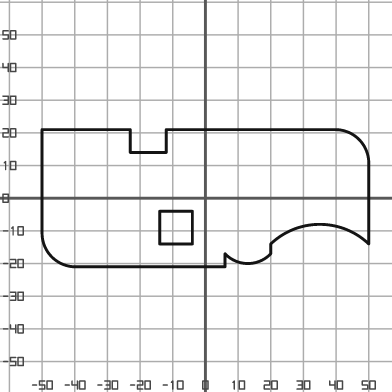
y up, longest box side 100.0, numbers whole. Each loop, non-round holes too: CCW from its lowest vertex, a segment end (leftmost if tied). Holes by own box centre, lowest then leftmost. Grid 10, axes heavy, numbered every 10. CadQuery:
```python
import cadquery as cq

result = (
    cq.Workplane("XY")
    .moveTo(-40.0, -21.0)
    .lineTo(6.0, -21.0)
    .lineTo(6.0, -17.0)
    .threePointArc((13.0, -20.0), (20.0, -17.0))
    .lineTo(20.0, -14.0)
    .threePointArc((35.0, -8.0), (50.0, -14.0))
    .lineTo(50.0, 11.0)
    .threePointArc((47.0, 18.0), (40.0, 21.0))
    .lineTo(-12.0, 21.0)
    .lineTo(-12.0, 14.0)
    .lineTo(-23.0, 14.0)
    .lineTo(-23.0, 21.0)
    .lineTo(-50.0, 21.0)
    .lineTo(-50.0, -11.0)
    .threePointArc((-47.0, -18.0), (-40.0, -21.0))
    .close()
    .moveTo(-14.0, -14.0)
    .lineTo(-4.0, -14.0)
    .lineTo(-4.0, -4.0)
    .lineTo(-14.0, -4.0)
    .close()
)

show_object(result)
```